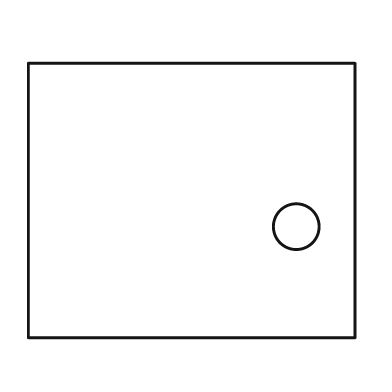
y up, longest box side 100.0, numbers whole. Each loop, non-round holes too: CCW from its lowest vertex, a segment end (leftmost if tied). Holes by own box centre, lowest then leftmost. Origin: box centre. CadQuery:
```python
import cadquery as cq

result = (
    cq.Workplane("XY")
    .moveTo(-50.0, -42.0)
    .lineTo(50.0, -42.0)
    .lineTo(50.0, 42.0)
    .lineTo(-50.0, 42.0)
    .close()
    .moveTo(32.0, -8.0)
    .circle(7.0)
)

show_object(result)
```